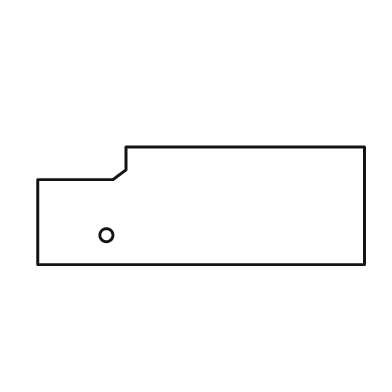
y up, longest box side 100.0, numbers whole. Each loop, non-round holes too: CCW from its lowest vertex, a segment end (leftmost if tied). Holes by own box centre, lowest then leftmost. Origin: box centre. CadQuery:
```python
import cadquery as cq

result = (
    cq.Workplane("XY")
    .moveTo(-50.0, -18.0)
    .lineTo(50.0, -18.0)
    .lineTo(50.0, 18.0)
    .lineTo(-23.0, 18.0)
    .lineTo(-23.0, 11.0)
    .lineTo(-27.0, 8.0)
    .lineTo(-50.0, 8.0)
    .close()
    .moveTo(-29.0, -9.0)
    .circle(2.0)
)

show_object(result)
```